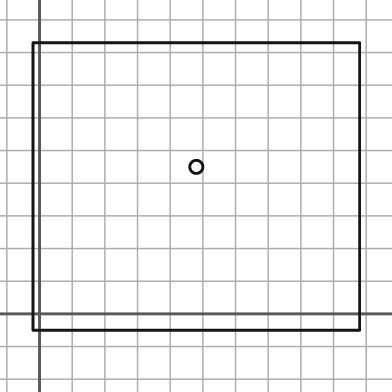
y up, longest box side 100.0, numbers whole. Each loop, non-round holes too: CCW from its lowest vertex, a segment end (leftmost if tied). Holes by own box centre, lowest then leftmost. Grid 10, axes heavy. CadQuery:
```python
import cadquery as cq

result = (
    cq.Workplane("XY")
    .moveTo(-2.0, -5.0)
    .lineTo(98.0, -5.0)
    .lineTo(98.0, 83.0)
    .lineTo(-2.0, 83.0)
    .close()
    .moveTo(48.0, 45.0)
    .circle(2.0)
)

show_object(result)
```